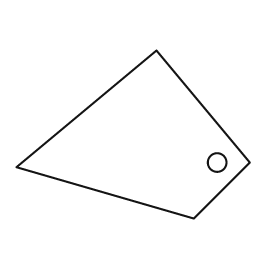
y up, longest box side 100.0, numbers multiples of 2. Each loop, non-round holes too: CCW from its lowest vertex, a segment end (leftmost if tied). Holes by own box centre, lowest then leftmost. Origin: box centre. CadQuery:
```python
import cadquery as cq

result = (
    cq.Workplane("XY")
    .moveTo(26.0, -36.0)
    .lineTo(50.0, -12.0)
    .lineTo(10.0, 36.0)
    .lineTo(-50.0, -14.0)
    .close()
    .moveTo(36.0, -12.0)
    .circle(4.0)
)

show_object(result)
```